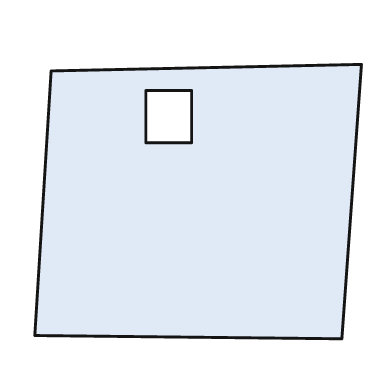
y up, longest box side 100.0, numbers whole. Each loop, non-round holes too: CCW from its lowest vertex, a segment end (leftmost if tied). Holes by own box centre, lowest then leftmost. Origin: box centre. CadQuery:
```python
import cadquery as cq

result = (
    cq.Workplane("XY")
    .moveTo(44.0, -42.0)
    .lineTo(50.0, 42.0)
    .lineTo(-45.0, 40.0)
    .lineTo(-50.0, -41.0)
    .close()
    .moveTo(-16.0, 18.0)
    .lineTo(-2.0, 18.0)
    .lineTo(-2.0, 34.0)
    .lineTo(-16.0, 34.0)
    .close()
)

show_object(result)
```